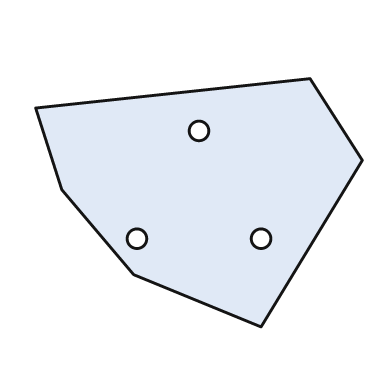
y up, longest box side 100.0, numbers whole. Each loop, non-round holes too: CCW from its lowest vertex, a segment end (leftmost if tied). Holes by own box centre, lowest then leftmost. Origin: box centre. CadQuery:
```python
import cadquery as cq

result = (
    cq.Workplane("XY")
    .moveTo(19.0, -38.0)
    .lineTo(50.0, 13.0)
    .lineTo(34.0, 38.0)
    .lineTo(-50.0, 29.0)
    .lineTo(-42.0, 4.0)
    .lineTo(-20.0, -22.0)
    .close()
    .moveTo(-19.0, -11.0)
    .circle(3.0)
    .moveTo(19.0, -11.0)
    .circle(3.0)
    .moveTo(0.0, 22.0)
    .circle(3.0)
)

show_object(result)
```